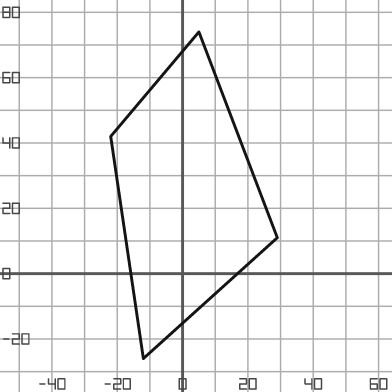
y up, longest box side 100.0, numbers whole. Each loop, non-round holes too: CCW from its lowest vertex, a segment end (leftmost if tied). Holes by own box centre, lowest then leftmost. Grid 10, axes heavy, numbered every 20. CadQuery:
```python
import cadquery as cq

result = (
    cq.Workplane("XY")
    .moveTo(-12.0, -26.0)
    .lineTo(29.0, 11.0)
    .lineTo(5.0, 74.0)
    .lineTo(-22.0, 42.0)
    .close()
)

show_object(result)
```